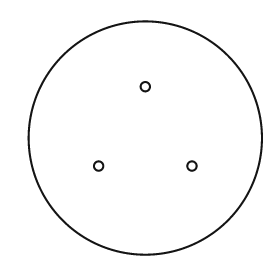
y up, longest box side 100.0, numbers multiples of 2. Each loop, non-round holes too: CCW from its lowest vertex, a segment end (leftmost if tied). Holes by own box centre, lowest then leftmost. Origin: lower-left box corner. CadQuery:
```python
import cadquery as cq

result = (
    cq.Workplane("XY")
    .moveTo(50.0, 50.0)
    .circle(50.0)
    .moveTo(30.0, 38.0)
    .circle(2.0)
    .moveTo(70.0, 38.0)
    .circle(2.0)
    .moveTo(50.0, 72.0)
    .circle(2.0)
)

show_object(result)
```